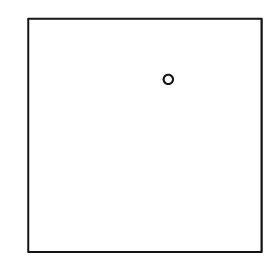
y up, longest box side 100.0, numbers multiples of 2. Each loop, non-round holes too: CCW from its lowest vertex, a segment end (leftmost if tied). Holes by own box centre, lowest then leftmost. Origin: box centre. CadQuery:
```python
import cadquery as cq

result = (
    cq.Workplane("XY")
    .moveTo(-50.0, -50.0)
    .lineTo(50.0, -50.0)
    .lineTo(50.0, 50.0)
    .lineTo(-50.0, 50.0)
    .close()
    .moveTo(10.0, 24.0)
    .circle(2.0)
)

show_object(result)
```